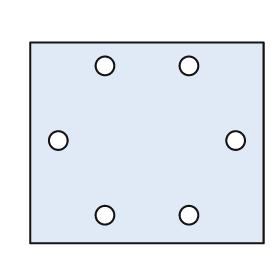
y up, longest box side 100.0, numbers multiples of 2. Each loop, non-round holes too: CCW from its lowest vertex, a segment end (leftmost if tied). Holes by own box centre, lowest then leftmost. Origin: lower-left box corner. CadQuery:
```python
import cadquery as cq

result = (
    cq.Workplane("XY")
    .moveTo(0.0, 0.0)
    .lineTo(100.0, 0.0)
    .lineTo(100.0, 86.0)
    .lineTo(0.0, 86.0)
    .close()
    .moveTo(32.0, 12.0)
    .circle(4.0)
    .moveTo(68.0, 12.0)
    .circle(4.0)
    .moveTo(12.0, 44.0)
    .circle(4.0)
    .moveTo(88.0, 44.0)
    .circle(4.0)
    .moveTo(32.0, 76.0)
    .circle(4.0)
    .moveTo(68.0, 76.0)
    .circle(4.0)
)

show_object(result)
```